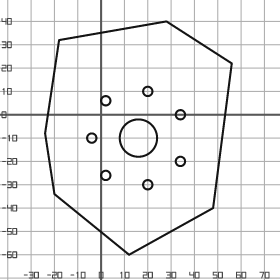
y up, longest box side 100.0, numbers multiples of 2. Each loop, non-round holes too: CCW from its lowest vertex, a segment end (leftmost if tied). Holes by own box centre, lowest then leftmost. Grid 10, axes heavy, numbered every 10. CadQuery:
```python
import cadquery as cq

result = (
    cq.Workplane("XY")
    .moveTo(12.0, -60.0)
    .lineTo(48.0, -40.0)
    .lineTo(56.0, 22.0)
    .lineTo(28.0, 40.0)
    .lineTo(-18.0, 32.0)
    .lineTo(-24.0, -8.0)
    .lineTo(-20.0, -34.0)
    .close()
    .moveTo(20.0, -30.0)
    .circle(2.0)
    .moveTo(2.0, -26.0)
    .circle(2.0)
    .moveTo(34.0, -20.0)
    .circle(2.0)
    .moveTo(-4.0, -10.0)
    .circle(2.0)
    .moveTo(16.0, -10.0)
    .circle(8.0)
    .moveTo(34.0, 0.0)
    .circle(2.0)
    .moveTo(2.0, 6.0)
    .circle(2.0)
    .moveTo(20.0, 10.0)
    .circle(2.0)
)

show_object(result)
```